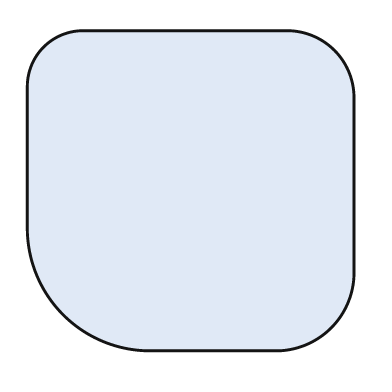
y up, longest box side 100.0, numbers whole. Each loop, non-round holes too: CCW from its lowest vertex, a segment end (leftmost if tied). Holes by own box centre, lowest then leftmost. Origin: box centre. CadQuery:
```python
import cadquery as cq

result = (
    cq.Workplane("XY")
    .moveTo(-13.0, -49.0)
    .lineTo(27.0, -49.0)
    .threePointArc((43.0, -42.0), (50.0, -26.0))
    .lineTo(50.0, 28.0)
    .threePointArc((44.0, 43.0), (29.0, 49.0))
    .lineTo(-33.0, 49.0)
    .threePointArc((-45.0, 44.0), (-50.0, 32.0))
    .lineTo(-50.0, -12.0)
    .threePointArc((-39.0, -38.0), (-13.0, -49.0))
    .close()
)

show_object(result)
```